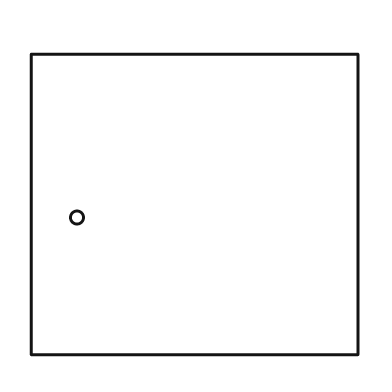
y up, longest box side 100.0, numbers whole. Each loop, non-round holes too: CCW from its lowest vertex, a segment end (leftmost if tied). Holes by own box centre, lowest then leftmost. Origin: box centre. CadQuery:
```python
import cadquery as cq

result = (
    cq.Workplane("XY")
    .moveTo(-50.0, -46.0)
    .lineTo(50.0, -46.0)
    .lineTo(50.0, 46.0)
    .lineTo(-50.0, 46.0)
    .close()
    .moveTo(-36.0, -4.0)
    .circle(2.0)
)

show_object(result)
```